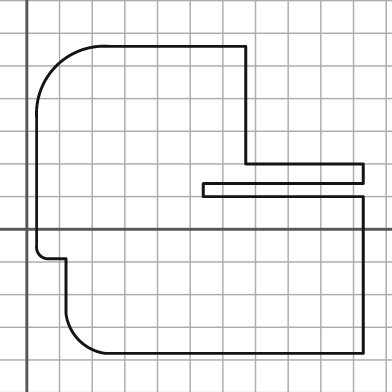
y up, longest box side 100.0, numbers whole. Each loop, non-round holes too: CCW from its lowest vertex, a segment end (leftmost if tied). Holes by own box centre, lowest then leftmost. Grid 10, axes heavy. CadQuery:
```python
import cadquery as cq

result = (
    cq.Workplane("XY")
    .moveTo(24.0, -38.0)
    .lineTo(103.0, -38.0)
    .lineTo(103.0, 10.0)
    .lineTo(54.0, 10.0)
    .lineTo(54.0, 14.0)
    .lineTo(103.0, 14.0)
    .lineTo(103.0, 20.0)
    .lineTo(67.0, 20.0)
    .lineTo(67.0, 56.0)
    .lineTo(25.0, 56.0)
    .threePointArc((9.0, 50.0), (3.0, 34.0))
    .lineTo(3.0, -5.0)
    .threePointArc((4.0, -8.0), (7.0, -9.0))
    .lineTo(12.0, -9.0)
    .lineTo(12.0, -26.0)
    .threePointArc((16.0, -34.0), (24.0, -38.0))
    .close()
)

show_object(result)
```